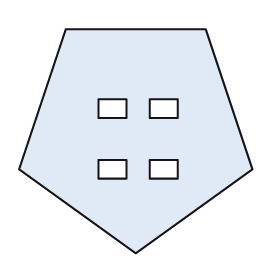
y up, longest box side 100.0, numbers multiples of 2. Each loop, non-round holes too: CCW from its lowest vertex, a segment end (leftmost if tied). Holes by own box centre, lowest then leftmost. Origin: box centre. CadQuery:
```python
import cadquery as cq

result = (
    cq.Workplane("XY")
    .moveTo(0.0, -48.0)
    .lineTo(50.0, -12.0)
    .lineTo(30.0, 48.0)
    .lineTo(-30.0, 48.0)
    .lineTo(-50.0, -12.0)
    .close()
    .moveTo(-16.0, -16.0)
    .lineTo(-4.0, -16.0)
    .lineTo(-4.0, -8.0)
    .lineTo(-16.0, -8.0)
    .close()
    .moveTo(6.0, -16.0)
    .lineTo(18.0, -16.0)
    .lineTo(18.0, -8.0)
    .lineTo(6.0, -8.0)
    .close()
    .moveTo(-16.0, 10.0)
    .lineTo(-4.0, 10.0)
    .lineTo(-4.0, 18.0)
    .lineTo(-16.0, 18.0)
    .close()
    .moveTo(6.0, 10.0)
    .lineTo(18.0, 10.0)
    .lineTo(18.0, 18.0)
    .lineTo(6.0, 18.0)
    .close()
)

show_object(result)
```